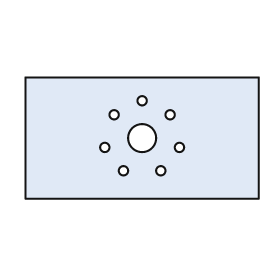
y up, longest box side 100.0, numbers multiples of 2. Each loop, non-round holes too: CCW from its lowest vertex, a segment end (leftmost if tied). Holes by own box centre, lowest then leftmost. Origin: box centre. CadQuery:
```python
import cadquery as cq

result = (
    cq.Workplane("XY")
    .moveTo(-50.0, -26.0)
    .lineTo(50.0, -26.0)
    .lineTo(50.0, 26.0)
    .lineTo(-50.0, 26.0)
    .close()
    .moveTo(-8.0, -14.0)
    .circle(2.0)
    .moveTo(8.0, -14.0)
    .circle(2.0)
    .moveTo(-16.0, -4.0)
    .circle(2.0)
    .moveTo(16.0, -4.0)
    .circle(2.0)
    .moveTo(0.0, 0.0)
    .circle(6.0)
    .moveTo(-12.0, 10.0)
    .circle(2.0)
    .moveTo(12.0, 10.0)
    .circle(2.0)
    .moveTo(0.0, 16.0)
    .circle(2.0)
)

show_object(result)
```